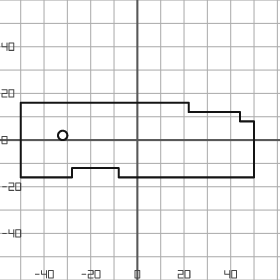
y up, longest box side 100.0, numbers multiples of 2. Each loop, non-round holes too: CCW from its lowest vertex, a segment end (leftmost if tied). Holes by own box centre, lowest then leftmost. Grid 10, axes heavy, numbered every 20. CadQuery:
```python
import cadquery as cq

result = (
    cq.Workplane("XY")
    .moveTo(-50.0, -16.0)
    .lineTo(-28.0, -16.0)
    .lineTo(-28.0, -12.0)
    .lineTo(-8.0, -12.0)
    .lineTo(-8.0, -16.0)
    .lineTo(50.0, -16.0)
    .lineTo(50.0, 8.0)
    .lineTo(44.0, 8.0)
    .lineTo(44.0, 12.0)
    .lineTo(22.0, 12.0)
    .lineTo(22.0, 16.0)
    .lineTo(-50.0, 16.0)
    .close()
    .moveTo(-32.0, 2.0)
    .circle(2.0)
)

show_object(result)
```